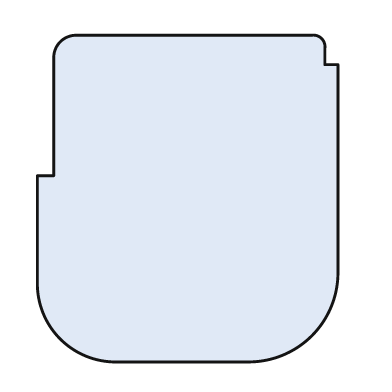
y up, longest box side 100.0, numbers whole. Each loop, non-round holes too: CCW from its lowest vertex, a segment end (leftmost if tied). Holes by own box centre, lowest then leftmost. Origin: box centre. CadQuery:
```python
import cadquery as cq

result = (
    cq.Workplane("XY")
    .moveTo(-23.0, -50.0)
    .lineTo(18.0, -50.0)
    .threePointArc((38.0, -42.0), (46.0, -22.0))
    .lineTo(46.0, 41.0)
    .lineTo(42.0, 41.0)
    .lineTo(42.0, 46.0)
    .threePointArc((41.0, 49.0), (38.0, 50.0))
    .lineTo(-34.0, 50.0)
    .threePointArc((-39.0, 48.0), (-41.0, 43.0))
    .lineTo(-41.0, 7.0)
    .lineTo(-46.0, 7.0)
    .lineTo(-46.0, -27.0)
    .threePointArc((-39.0, -43.0), (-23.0, -50.0))
    .close()
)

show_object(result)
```